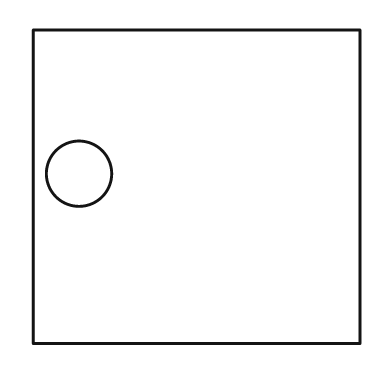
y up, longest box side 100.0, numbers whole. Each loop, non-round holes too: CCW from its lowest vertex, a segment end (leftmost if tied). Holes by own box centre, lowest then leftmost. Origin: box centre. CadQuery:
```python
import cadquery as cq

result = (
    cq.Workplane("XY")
    .moveTo(-50.0, -48.0)
    .lineTo(50.0, -48.0)
    .lineTo(50.0, 48.0)
    .lineTo(-50.0, 48.0)
    .close()
    .moveTo(-36.0, 4.0)
    .circle(10.0)
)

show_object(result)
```